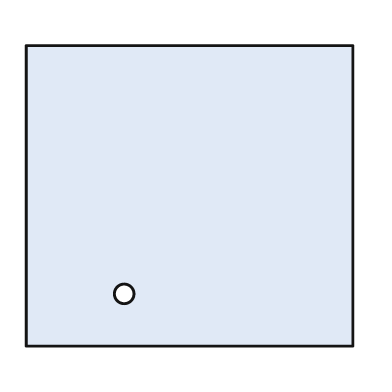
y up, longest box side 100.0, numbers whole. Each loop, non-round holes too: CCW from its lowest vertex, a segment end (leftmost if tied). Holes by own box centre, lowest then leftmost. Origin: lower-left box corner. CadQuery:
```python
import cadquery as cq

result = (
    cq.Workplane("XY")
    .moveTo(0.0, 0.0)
    .lineTo(100.0, 0.0)
    .lineTo(100.0, 92.0)
    .lineTo(0.0, 92.0)
    .close()
    .moveTo(30.0, 16.0)
    .circle(3.0)
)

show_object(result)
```